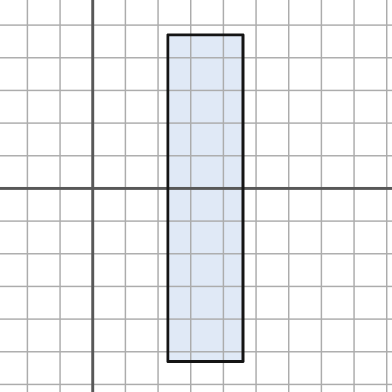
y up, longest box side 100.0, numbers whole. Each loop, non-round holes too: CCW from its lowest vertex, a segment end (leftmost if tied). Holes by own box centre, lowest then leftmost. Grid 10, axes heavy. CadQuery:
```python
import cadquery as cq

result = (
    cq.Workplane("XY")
    .moveTo(23.0, -53.0)
    .lineTo(46.0, -53.0)
    .lineTo(46.0, 47.0)
    .lineTo(23.0, 47.0)
    .close()
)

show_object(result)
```